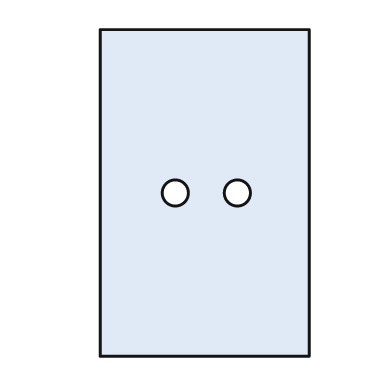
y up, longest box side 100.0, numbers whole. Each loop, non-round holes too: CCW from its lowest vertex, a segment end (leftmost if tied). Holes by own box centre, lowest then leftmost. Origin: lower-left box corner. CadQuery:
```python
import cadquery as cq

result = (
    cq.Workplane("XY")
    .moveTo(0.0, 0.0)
    .lineTo(64.0, 0.0)
    .lineTo(64.0, 100.0)
    .lineTo(0.0, 100.0)
    .close()
    .moveTo(23.0, 50.0)
    .circle(4.0)
    .moveTo(42.0, 50.0)
    .circle(4.0)
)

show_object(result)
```